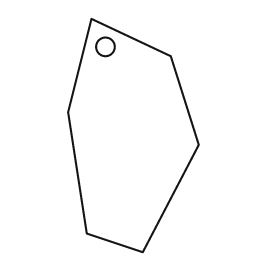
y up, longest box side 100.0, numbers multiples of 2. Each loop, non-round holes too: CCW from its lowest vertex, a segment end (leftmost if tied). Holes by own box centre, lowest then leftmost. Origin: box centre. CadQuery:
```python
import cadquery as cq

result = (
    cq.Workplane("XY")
    .moveTo(4.0, -50.0)
    .lineTo(28.0, -4.0)
    .lineTo(16.0, 34.0)
    .lineTo(-18.0, 50.0)
    .lineTo(-28.0, 10.0)
    .lineTo(-20.0, -42.0)
    .close()
    .moveTo(-12.0, 38.0)
    .circle(4.0)
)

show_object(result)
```